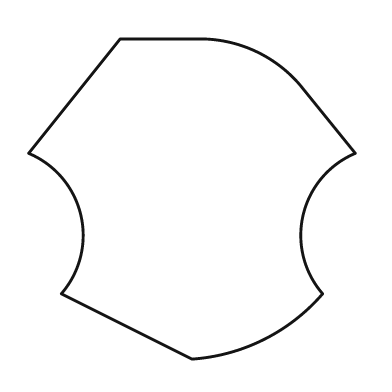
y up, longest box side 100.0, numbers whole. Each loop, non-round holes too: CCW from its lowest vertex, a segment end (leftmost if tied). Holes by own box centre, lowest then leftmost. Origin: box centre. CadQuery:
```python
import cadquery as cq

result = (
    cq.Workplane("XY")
    .moveTo(0.0, -49.0)
    .threePointArc((22.0, -43.0), (40.0, -29.0))
    .threePointArc((34.0, -5.0), (50.0, 14.0))
    .lineTo(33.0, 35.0)
    .threePointArc((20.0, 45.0), (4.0, 49.0))
    .lineTo(-22.0, 49.0)
    .lineTo(-50.0, 14.0)
    .threePointArc((-34.0, -5.0), (-40.0, -29.0))
    .close()
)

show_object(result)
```